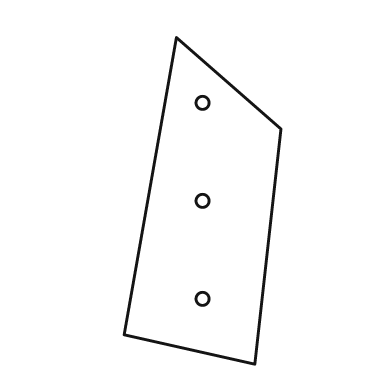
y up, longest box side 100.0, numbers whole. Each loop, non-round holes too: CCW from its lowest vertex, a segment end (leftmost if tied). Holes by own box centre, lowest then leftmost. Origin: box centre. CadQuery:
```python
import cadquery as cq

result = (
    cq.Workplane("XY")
    .moveTo(16.0, -50.0)
    .lineTo(24.0, 22.0)
    .lineTo(-8.0, 50.0)
    .lineTo(-24.0, -41.0)
    .close()
    .moveTo(0.0, -30.0)
    .circle(2.0)
    .moveTo(0.0, 0.0)
    .circle(2.0)
    .moveTo(0.0, 30.0)
    .circle(2.0)
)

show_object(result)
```